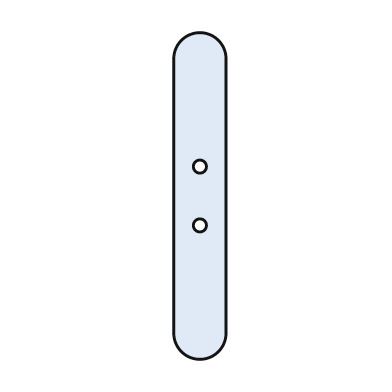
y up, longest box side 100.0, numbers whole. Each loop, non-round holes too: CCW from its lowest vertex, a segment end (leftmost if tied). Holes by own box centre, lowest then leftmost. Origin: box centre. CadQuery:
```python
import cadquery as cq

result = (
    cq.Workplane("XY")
    .moveTo(-8.0, -42.0)
    .threePointArc((0.0, -50.0), (8.0, -42.0))
    .lineTo(8.0, 42.0)
    .threePointArc((0.0, 50.0), (-8.0, 42.0))
    .close()
    .moveTo(0.0, -9.0)
    .circle(2.0)
    .moveTo(0.0, 9.0)
    .circle(2.0)
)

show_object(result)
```